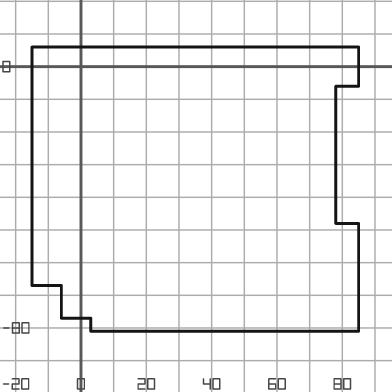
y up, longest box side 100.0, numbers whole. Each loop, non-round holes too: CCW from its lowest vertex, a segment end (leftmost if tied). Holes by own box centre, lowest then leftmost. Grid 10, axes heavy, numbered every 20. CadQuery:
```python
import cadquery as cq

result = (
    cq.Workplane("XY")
    .moveTo(3.0, -81.0)
    .lineTo(85.0, -81.0)
    .lineTo(85.0, -48.0)
    .lineTo(78.0, -48.0)
    .lineTo(78.0, -6.0)
    .lineTo(85.0, -6.0)
    .lineTo(85.0, 6.0)
    .lineTo(-15.0, 6.0)
    .lineTo(-15.0, -67.0)
    .lineTo(-6.0, -67.0)
    .lineTo(-6.0, -77.0)
    .lineTo(3.0, -77.0)
    .close()
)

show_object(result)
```